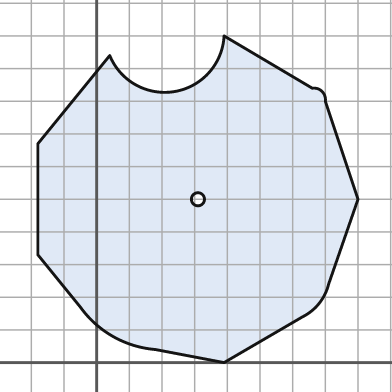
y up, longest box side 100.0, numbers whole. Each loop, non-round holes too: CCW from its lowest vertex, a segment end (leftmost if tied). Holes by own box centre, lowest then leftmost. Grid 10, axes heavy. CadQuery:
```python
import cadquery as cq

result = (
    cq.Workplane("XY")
    .moveTo(39.0, 0.0)
    .lineTo(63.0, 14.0)
    .threePointArc((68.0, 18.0), (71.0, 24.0))
    .lineTo(80.0, 50.0)
    .lineTo(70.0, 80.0)
    .threePointArc((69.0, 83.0), (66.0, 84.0))
    .lineTo(39.0, 100.0)
    .threePointArc((24.0, 83.0), (4.0, 94.0))
    .lineTo(-18.0, 67.0)
    .lineTo(-18.0, 33.0)
    .lineTo(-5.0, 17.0)
    .threePointArc((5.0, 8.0), (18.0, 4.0))
    .close()
    .moveTo(31.0, 50.0)
    .circle(2.0)
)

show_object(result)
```